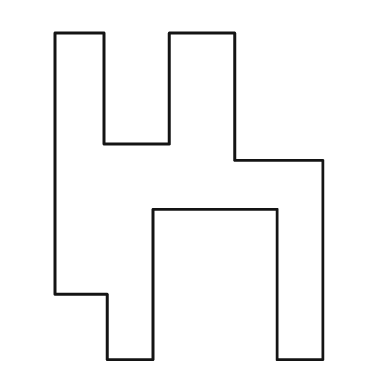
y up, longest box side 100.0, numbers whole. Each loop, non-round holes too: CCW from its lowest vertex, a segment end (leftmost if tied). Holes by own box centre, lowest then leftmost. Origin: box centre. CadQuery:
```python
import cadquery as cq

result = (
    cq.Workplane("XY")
    .moveTo(-25.0, -50.0)
    .lineTo(-11.0, -50.0)
    .lineTo(-11.0, -4.0)
    .lineTo(27.0, -4.0)
    .lineTo(27.0, -50.0)
    .lineTo(41.0, -50.0)
    .lineTo(41.0, 11.0)
    .lineTo(14.0, 11.0)
    .lineTo(14.0, 50.0)
    .lineTo(-6.0, 50.0)
    .lineTo(-6.0, 16.0)
    .lineTo(-26.0, 16.0)
    .lineTo(-26.0, 50.0)
    .lineTo(-41.0, 50.0)
    .lineTo(-41.0, -30.0)
    .lineTo(-25.0, -30.0)
    .close()
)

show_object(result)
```